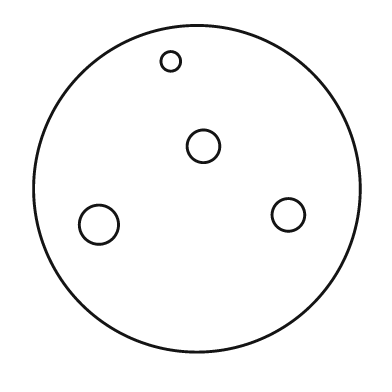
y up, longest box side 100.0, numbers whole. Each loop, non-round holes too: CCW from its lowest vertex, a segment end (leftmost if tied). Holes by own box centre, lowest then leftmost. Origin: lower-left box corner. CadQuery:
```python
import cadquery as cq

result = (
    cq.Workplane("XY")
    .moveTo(50.0, 50.0)
    .circle(50.0)
    .moveTo(20.0, 39.0)
    .circle(6.0)
    .moveTo(78.0, 42.0)
    .circle(5.0)
    .moveTo(52.0, 63.0)
    .circle(5.0)
    .moveTo(42.0, 89.0)
    .circle(3.0)
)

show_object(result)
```